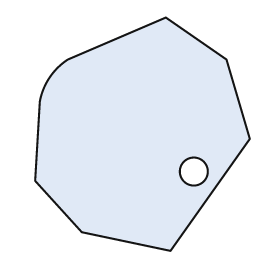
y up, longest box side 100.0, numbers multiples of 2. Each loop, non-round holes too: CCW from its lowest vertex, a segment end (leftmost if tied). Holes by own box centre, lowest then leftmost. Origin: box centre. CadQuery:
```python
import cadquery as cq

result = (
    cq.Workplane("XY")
    .moveTo(12.0, -50.0)
    .lineTo(46.0, -2.0)
    .lineTo(36.0, 32.0)
    .lineTo(10.0, 50.0)
    .lineTo(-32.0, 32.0)
    .threePointArc((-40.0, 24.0), (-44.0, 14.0))
    .lineTo(-46.0, -20.0)
    .lineTo(-26.0, -42.0)
    .close()
    .moveTo(22.0, -16.0)
    .circle(6.0)
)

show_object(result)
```